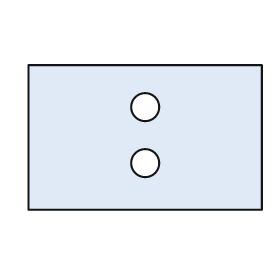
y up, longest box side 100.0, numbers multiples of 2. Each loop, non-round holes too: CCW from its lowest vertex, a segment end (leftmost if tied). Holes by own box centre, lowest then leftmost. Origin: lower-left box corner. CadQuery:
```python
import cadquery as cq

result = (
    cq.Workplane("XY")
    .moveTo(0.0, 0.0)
    .lineTo(100.0, 0.0)
    .lineTo(100.0, 62.0)
    .lineTo(0.0, 62.0)
    .close()
    .moveTo(50.0, 20.0)
    .circle(6.0)
    .moveTo(50.0, 44.0)
    .circle(6.0)
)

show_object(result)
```